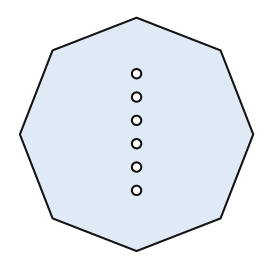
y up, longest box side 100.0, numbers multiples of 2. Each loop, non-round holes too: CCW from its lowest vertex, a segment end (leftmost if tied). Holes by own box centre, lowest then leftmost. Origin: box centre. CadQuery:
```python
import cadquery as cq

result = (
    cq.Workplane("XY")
    .moveTo(0.0, -50.0)
    .lineTo(36.0, -36.0)
    .lineTo(50.0, 0.0)
    .lineTo(36.0, 36.0)
    .lineTo(0.0, 50.0)
    .lineTo(-36.0, 36.0)
    .lineTo(-50.0, 0.0)
    .lineTo(-36.0, -36.0)
    .close()
    .moveTo(0.0, -24.0)
    .circle(2.0)
    .moveTo(0.0, -14.0)
    .circle(2.0)
    .moveTo(0.0, -4.0)
    .circle(2.0)
    .moveTo(0.0, 6.0)
    .circle(2.0)
    .moveTo(0.0, 16.0)
    .circle(2.0)
    .moveTo(0.0, 26.0)
    .circle(2.0)
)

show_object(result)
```